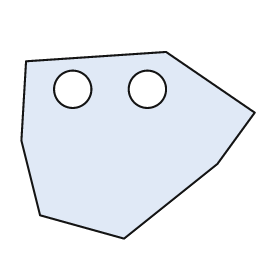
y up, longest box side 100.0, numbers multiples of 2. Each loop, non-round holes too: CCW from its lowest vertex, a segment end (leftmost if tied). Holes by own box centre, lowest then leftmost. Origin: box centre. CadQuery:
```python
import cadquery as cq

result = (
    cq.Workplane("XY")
    .moveTo(-6.0, -40.0)
    .lineTo(34.0, -8.0)
    .lineTo(50.0, 14.0)
    .lineTo(12.0, 40.0)
    .lineTo(-48.0, 36.0)
    .lineTo(-50.0, 2.0)
    .lineTo(-42.0, -30.0)
    .close()
    .moveTo(-28.0, 24.0)
    .circle(8.0)
    .moveTo(4.0, 24.0)
    .circle(8.0)
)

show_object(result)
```